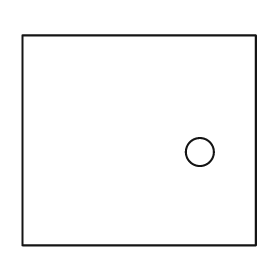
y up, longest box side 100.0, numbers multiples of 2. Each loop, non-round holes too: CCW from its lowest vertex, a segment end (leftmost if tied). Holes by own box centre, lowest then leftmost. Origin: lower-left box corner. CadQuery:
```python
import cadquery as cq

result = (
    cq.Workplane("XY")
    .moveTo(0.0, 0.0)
    .lineTo(100.0, 0.0)
    .lineTo(100.0, 90.0)
    .lineTo(0.0, 90.0)
    .close()
    .moveTo(76.0, 40.0)
    .circle(6.0)
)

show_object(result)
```